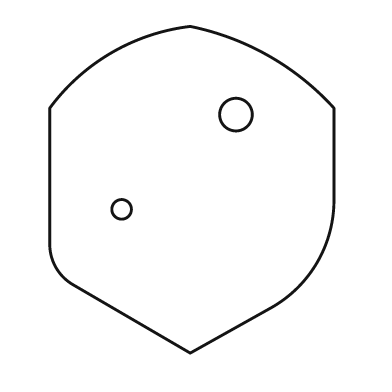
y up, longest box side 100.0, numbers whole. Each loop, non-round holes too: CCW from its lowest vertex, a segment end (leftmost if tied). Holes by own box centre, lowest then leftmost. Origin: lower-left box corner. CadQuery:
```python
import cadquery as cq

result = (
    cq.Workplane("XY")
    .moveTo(43.0, 0.0)
    .lineTo(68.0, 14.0)
    .threePointArc((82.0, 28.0), (87.0, 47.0))
    .lineTo(87.0, 75.0)
    .threePointArc((67.0, 91.0), (43.0, 100.0))
    .threePointArc((19.0, 92.0), (0.0, 75.0))
    .lineTo(0.0, 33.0)
    .threePointArc((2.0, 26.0), (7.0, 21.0))
    .close()
    .moveTo(22.0, 44.0)
    .circle(3.0)
    .moveTo(57.0, 73.0)
    .circle(5.0)
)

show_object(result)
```